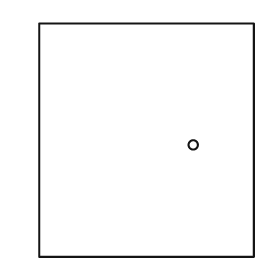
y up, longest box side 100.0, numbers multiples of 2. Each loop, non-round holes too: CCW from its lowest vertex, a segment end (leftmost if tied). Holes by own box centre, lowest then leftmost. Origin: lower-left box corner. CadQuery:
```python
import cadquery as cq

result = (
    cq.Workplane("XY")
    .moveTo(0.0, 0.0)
    .lineTo(92.0, 0.0)
    .lineTo(92.0, 100.0)
    .lineTo(0.0, 100.0)
    .close()
    .moveTo(66.0, 48.0)
    .circle(2.0)
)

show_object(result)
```